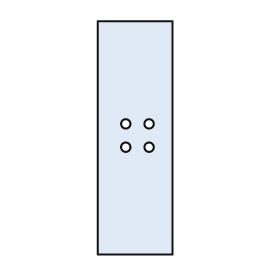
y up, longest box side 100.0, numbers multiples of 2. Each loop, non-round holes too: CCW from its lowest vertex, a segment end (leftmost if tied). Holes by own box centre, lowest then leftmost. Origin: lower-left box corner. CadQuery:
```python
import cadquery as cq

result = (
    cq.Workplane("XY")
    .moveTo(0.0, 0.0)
    .lineTo(32.0, 0.0)
    .lineTo(32.0, 100.0)
    .lineTo(0.0, 100.0)
    .close()
    .moveTo(12.0, 46.0)
    .circle(2.0)
    .moveTo(22.0, 46.0)
    .circle(2.0)
    .moveTo(12.0, 56.0)
    .circle(2.0)
    .moveTo(22.0, 56.0)
    .circle(2.0)
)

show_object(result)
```